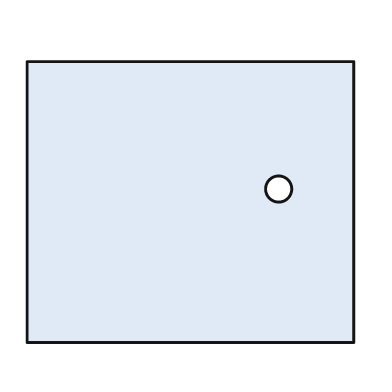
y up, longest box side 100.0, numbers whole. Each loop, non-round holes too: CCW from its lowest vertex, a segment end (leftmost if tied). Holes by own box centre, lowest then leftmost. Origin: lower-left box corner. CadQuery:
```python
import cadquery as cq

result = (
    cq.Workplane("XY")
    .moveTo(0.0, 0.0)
    .lineTo(100.0, 0.0)
    .lineTo(100.0, 86.0)
    .lineTo(0.0, 86.0)
    .close()
    .moveTo(77.0, 47.0)
    .circle(4.0)
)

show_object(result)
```